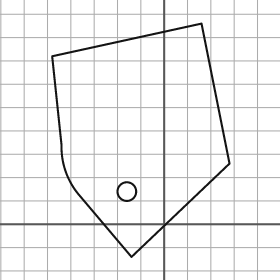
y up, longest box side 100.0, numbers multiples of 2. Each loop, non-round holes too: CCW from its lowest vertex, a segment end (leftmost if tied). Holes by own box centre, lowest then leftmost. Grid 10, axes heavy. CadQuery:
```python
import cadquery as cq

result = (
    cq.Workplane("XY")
    .moveTo(-14.0, -14.0)
    .lineTo(28.0, 26.0)
    .lineTo(16.0, 86.0)
    .lineTo(-48.0, 72.0)
    .lineTo(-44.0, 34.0)
    .threePointArc((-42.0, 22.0), (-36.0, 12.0))
    .close()
    .moveTo(-16.0, 14.0)
    .circle(4.0)
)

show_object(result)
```